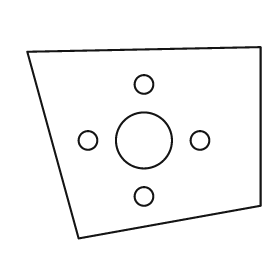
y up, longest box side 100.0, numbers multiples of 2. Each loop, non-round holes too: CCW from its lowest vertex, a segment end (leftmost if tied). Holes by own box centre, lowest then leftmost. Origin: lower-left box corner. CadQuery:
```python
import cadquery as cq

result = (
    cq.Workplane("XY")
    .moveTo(22.0, 0.0)
    .lineTo(100.0, 14.0)
    .lineTo(100.0, 82.0)
    .lineTo(0.0, 80.0)
    .close()
    .moveTo(50.0, 18.0)
    .circle(4.0)
    .moveTo(26.0, 42.0)
    .circle(4.0)
    .moveTo(50.0, 42.0)
    .circle(12.0)
    .moveTo(74.0, 42.0)
    .circle(4.0)
    .moveTo(50.0, 66.0)
    .circle(4.0)
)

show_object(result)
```